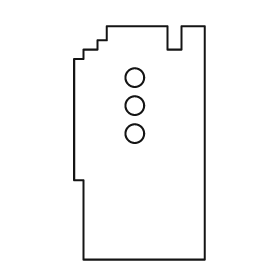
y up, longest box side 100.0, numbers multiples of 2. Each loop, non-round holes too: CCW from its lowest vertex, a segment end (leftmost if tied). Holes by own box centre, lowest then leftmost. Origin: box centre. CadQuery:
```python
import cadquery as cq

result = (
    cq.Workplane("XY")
    .moveTo(-24.0, -50.0)
    .lineTo(28.0, -50.0)
    .lineTo(28.0, 50.0)
    .lineTo(18.0, 50.0)
    .lineTo(18.0, 40.0)
    .lineTo(12.0, 40.0)
    .lineTo(12.0, 50.0)
    .lineTo(-14.0, 50.0)
    .lineTo(-14.0, 44.0)
    .lineTo(-18.0, 44.0)
    .lineTo(-18.0, 40.0)
    .lineTo(-24.0, 40.0)
    .lineTo(-24.0, 36.0)
    .lineTo(-28.0, 36.0)
    .lineTo(-28.0, -16.0)
    .lineTo(-24.0, -16.0)
    .close()
    .moveTo(-2.0, 4.0)
    .circle(4.0)
    .moveTo(-2.0, 16.0)
    .circle(4.0)
    .moveTo(-2.0, 28.0)
    .circle(4.0)
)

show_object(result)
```